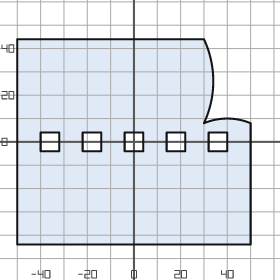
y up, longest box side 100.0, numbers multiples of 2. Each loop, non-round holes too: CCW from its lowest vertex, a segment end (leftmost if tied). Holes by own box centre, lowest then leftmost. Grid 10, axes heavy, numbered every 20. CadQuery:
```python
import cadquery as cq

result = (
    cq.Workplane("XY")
    .moveTo(-50.0, -44.0)
    .lineTo(50.0, -44.0)
    .lineTo(50.0, 8.0)
    .threePointArc((40.0, 10.0), (30.0, 8.0))
    .threePointArc((34.0, 26.0), (30.0, 44.0))
    .lineTo(-50.0, 44.0)
    .close()
    .moveTo(-40.0, -4.0)
    .lineTo(-32.0, -4.0)
    .lineTo(-32.0, 4.0)
    .lineTo(-40.0, 4.0)
    .close()
    .moveTo(-22.0, -4.0)
    .lineTo(-14.0, -4.0)
    .lineTo(-14.0, 4.0)
    .lineTo(-22.0, 4.0)
    .close()
    .moveTo(-4.0, -4.0)
    .lineTo(4.0, -4.0)
    .lineTo(4.0, 4.0)
    .lineTo(-4.0, 4.0)
    .close()
    .moveTo(14.0, -4.0)
    .lineTo(22.0, -4.0)
    .lineTo(22.0, 4.0)
    .lineTo(14.0, 4.0)
    .close()
    .moveTo(32.0, -4.0)
    .lineTo(40.0, -4.0)
    .lineTo(40.0, 4.0)
    .lineTo(32.0, 4.0)
    .close()
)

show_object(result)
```